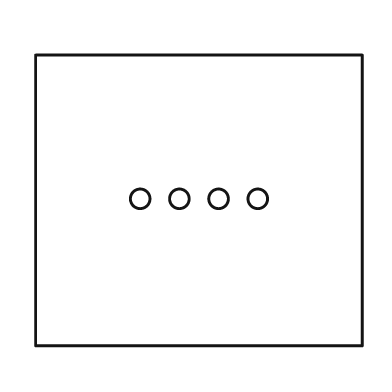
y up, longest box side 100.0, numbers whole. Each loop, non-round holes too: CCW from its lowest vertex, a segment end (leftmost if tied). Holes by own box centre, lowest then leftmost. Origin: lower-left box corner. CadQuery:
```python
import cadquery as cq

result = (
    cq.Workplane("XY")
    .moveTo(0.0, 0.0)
    .lineTo(100.0, 0.0)
    .lineTo(100.0, 89.0)
    .lineTo(0.0, 89.0)
    .close()
    .moveTo(32.0, 45.0)
    .circle(3.0)
    .moveTo(44.0, 45.0)
    .circle(3.0)
    .moveTo(56.0, 45.0)
    .circle(3.0)
    .moveTo(68.0, 45.0)
    .circle(3.0)
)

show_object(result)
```